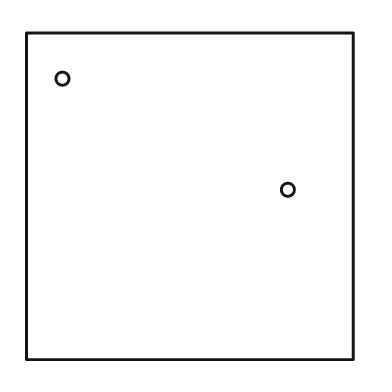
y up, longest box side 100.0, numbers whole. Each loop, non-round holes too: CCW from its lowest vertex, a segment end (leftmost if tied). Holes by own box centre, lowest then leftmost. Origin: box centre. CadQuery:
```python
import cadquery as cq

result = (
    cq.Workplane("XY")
    .moveTo(-50.0, -50.0)
    .lineTo(50.0, -50.0)
    .lineTo(50.0, 50.0)
    .lineTo(-50.0, 50.0)
    .close()
    .moveTo(30.0, 2.0)
    .circle(2.0)
    .moveTo(-39.0, 36.0)
    .circle(2.0)
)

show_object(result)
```